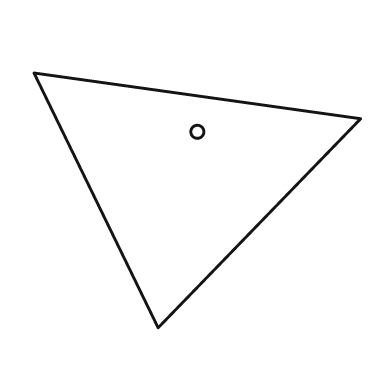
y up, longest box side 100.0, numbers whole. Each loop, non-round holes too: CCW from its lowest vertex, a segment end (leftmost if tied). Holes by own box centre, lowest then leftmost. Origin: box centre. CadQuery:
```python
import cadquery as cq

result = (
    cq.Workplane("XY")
    .moveTo(-12.0, -39.0)
    .lineTo(50.0, 25.0)
    .lineTo(-50.0, 39.0)
    .close()
    .moveTo(0.0, 21.0)
    .circle(2.0)
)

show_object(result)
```